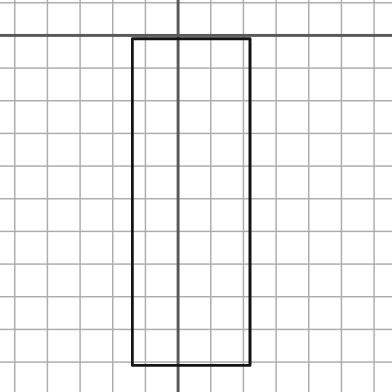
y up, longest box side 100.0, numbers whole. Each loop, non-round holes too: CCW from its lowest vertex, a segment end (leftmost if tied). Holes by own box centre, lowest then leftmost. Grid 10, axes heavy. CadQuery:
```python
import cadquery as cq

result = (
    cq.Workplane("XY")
    .moveTo(-14.0, -101.0)
    .lineTo(22.0, -101.0)
    .lineTo(22.0, -1.0)
    .lineTo(-14.0, -1.0)
    .close()
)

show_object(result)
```